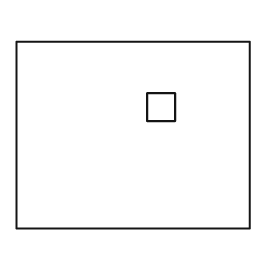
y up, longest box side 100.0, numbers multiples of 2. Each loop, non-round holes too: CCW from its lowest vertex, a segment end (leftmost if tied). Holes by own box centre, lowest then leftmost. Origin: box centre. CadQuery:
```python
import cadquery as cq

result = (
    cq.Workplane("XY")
    .moveTo(-50.0, -40.0)
    .lineTo(50.0, -40.0)
    .lineTo(50.0, 40.0)
    .lineTo(-50.0, 40.0)
    .close()
    .moveTo(6.0, 6.0)
    .lineTo(18.0, 6.0)
    .lineTo(18.0, 18.0)
    .lineTo(6.0, 18.0)
    .close()
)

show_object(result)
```